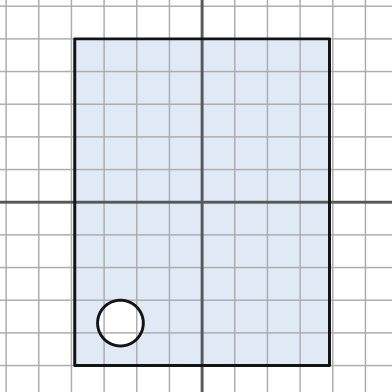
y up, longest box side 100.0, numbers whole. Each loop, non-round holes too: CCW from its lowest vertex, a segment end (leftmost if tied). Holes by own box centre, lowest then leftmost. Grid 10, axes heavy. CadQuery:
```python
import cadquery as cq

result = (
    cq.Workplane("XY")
    .moveTo(-39.0, -50.0)
    .lineTo(39.0, -50.0)
    .lineTo(39.0, 50.0)
    .lineTo(-39.0, 50.0)
    .close()
    .moveTo(-25.0, -37.0)
    .circle(7.0)
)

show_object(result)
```